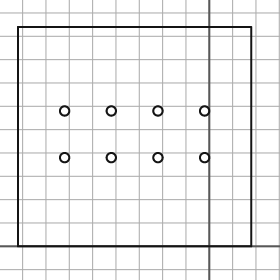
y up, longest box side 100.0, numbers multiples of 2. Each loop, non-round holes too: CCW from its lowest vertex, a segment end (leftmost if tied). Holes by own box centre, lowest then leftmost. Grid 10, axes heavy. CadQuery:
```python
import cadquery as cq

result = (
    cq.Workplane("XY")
    .moveTo(-82.0, 0.0)
    .lineTo(18.0, 0.0)
    .lineTo(18.0, 94.0)
    .lineTo(-82.0, 94.0)
    .close()
    .moveTo(-62.0, 38.0)
    .circle(2.0)
    .moveTo(-42.0, 38.0)
    .circle(2.0)
    .moveTo(-22.0, 38.0)
    .circle(2.0)
    .moveTo(-2.0, 38.0)
    .circle(2.0)
    .moveTo(-62.0, 58.0)
    .circle(2.0)
    .moveTo(-42.0, 58.0)
    .circle(2.0)
    .moveTo(-22.0, 58.0)
    .circle(2.0)
    .moveTo(-2.0, 58.0)
    .circle(2.0)
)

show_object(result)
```